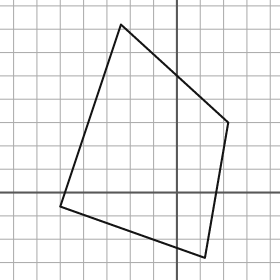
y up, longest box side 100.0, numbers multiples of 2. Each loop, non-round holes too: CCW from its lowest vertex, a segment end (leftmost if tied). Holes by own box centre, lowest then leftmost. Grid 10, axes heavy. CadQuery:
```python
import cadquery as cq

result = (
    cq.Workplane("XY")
    .moveTo(12.0, -28.0)
    .lineTo(22.0, 30.0)
    .lineTo(-24.0, 72.0)
    .lineTo(-50.0, -6.0)
    .close()
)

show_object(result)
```